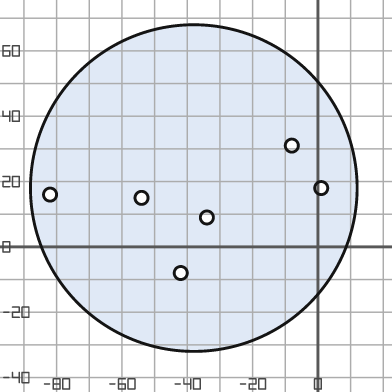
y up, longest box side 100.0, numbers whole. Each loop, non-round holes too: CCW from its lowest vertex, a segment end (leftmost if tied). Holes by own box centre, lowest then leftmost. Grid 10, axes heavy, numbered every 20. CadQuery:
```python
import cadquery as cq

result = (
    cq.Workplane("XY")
    .moveTo(-38.0, 18.0)
    .circle(50.0)
    .moveTo(-42.0, -8.0)
    .circle(2.0)
    .moveTo(-34.0, 9.0)
    .circle(2.0)
    .moveTo(-54.0, 15.0)
    .circle(2.0)
    .moveTo(-82.0, 16.0)
    .circle(2.0)
    .moveTo(1.0, 18.0)
    .circle(2.0)
    .moveTo(-8.0, 31.0)
    .circle(2.0)
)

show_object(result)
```